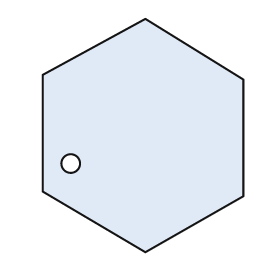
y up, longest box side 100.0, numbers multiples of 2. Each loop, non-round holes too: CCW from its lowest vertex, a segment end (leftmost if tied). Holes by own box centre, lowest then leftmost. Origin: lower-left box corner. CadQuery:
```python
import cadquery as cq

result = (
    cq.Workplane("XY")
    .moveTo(44.0, 0.0)
    .lineTo(86.0, 24.0)
    .lineTo(86.0, 74.0)
    .lineTo(44.0, 100.0)
    .lineTo(0.0, 76.0)
    .lineTo(0.0, 26.0)
    .close()
    .moveTo(12.0, 38.0)
    .circle(4.0)
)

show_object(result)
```